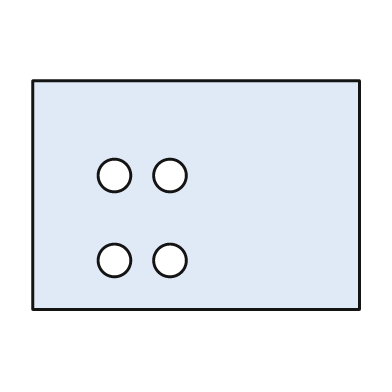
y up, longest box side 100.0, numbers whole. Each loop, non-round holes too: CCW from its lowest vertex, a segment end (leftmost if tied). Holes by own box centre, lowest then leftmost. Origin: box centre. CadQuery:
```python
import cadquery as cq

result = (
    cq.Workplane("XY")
    .moveTo(-50.0, -35.0)
    .lineTo(50.0, -35.0)
    .lineTo(50.0, 35.0)
    .lineTo(-50.0, 35.0)
    .close()
    .moveTo(-25.0, -20.0)
    .circle(5.0)
    .moveTo(-8.0, -20.0)
    .circle(5.0)
    .moveTo(-25.0, 6.0)
    .circle(5.0)
    .moveTo(-8.0, 6.0)
    .circle(5.0)
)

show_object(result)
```